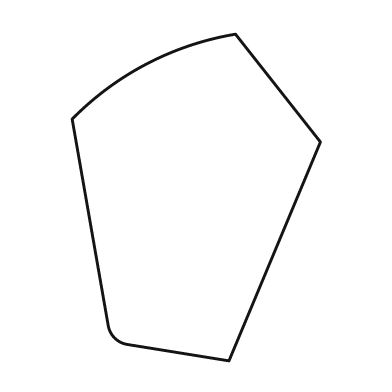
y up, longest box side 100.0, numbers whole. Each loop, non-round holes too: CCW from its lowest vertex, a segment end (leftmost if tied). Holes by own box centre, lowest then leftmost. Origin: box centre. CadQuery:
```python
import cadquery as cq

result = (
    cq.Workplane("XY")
    .moveTo(10.0, -50.0)
    .lineTo(38.0, 17.0)
    .lineTo(12.0, 50.0)
    .threePointArc((-15.0, 41.0), (-38.0, 24.0))
    .lineTo(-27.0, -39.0)
    .threePointArc((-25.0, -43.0), (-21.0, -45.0))
    .close()
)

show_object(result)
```